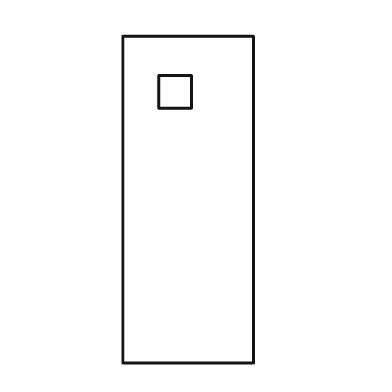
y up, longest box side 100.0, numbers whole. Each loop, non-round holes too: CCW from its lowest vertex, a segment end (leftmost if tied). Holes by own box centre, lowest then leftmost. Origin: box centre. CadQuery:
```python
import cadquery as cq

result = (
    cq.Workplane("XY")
    .moveTo(-20.0, -50.0)
    .lineTo(20.0, -50.0)
    .lineTo(20.0, 50.0)
    .lineTo(-20.0, 50.0)
    .close()
    .moveTo(-9.0, 28.0)
    .lineTo(1.0, 28.0)
    .lineTo(1.0, 38.0)
    .lineTo(-9.0, 38.0)
    .close()
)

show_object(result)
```